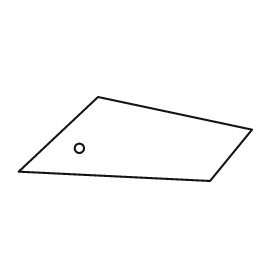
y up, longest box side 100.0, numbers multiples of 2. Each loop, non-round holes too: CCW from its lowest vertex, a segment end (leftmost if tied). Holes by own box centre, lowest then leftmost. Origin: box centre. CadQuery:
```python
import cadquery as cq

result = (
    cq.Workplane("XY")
    .moveTo(32.0, -18.0)
    .lineTo(50.0, 4.0)
    .lineTo(-16.0, 18.0)
    .lineTo(-50.0, -14.0)
    .close()
    .moveTo(-24.0, -4.0)
    .circle(2.0)
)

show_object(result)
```